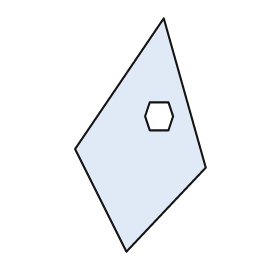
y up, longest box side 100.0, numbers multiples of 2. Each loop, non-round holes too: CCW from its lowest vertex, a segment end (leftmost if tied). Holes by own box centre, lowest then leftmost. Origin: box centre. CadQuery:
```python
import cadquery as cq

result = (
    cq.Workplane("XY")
    .moveTo(-6.0, -50.0)
    .lineTo(28.0, -14.0)
    .lineTo(10.0, 50.0)
    .lineTo(-28.0, -6.0)
    .close()
    .moveTo(4.0, 2.0)
    .lineTo(12.0, 2.0)
    .lineTo(14.0, 8.0)
    .lineTo(12.0, 14.0)
    .lineTo(4.0, 14.0)
    .lineTo(2.0, 8.0)
    .close()
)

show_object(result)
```